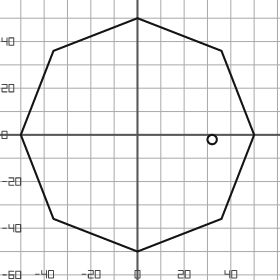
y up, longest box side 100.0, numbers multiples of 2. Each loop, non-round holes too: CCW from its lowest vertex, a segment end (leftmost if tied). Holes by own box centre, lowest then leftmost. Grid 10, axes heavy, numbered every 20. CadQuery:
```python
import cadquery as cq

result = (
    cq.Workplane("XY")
    .moveTo(0.0, -50.0)
    .lineTo(36.0, -36.0)
    .lineTo(50.0, 0.0)
    .lineTo(36.0, 36.0)
    .lineTo(0.0, 50.0)
    .lineTo(-36.0, 36.0)
    .lineTo(-50.0, 0.0)
    .lineTo(-36.0, -36.0)
    .close()
    .moveTo(32.0, -2.0)
    .circle(2.0)
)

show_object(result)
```